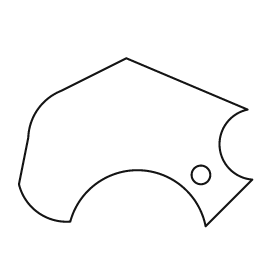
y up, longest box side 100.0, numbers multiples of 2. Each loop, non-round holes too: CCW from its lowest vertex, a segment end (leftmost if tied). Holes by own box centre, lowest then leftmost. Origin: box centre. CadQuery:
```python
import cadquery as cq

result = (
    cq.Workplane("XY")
    .moveTo(30.0, -36.0)
    .lineTo(50.0, -16.0)
    .threePointArc((36.0, -2.0), (48.0, 14.0))
    .lineTo(-4.0, 36.0)
    .lineTo(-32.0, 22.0)
    .threePointArc((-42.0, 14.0), (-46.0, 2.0))
    .lineTo(-50.0, -18.0)
    .threePointArc((-42.0, -30.0), (-28.0, -34.0))
    .threePointArc((2.0, -12.0), (30.0, -36.0))
    .close()
    .moveTo(28.0, -14.0)
    .circle(4.0)
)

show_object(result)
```